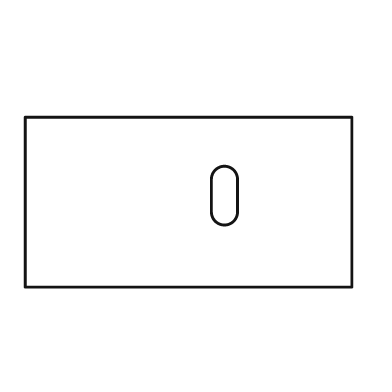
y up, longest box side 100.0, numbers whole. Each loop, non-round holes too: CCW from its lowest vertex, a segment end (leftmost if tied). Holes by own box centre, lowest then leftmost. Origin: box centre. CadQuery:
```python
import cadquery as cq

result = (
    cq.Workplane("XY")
    .moveTo(-50.0, -26.0)
    .lineTo(50.0, -26.0)
    .lineTo(50.0, 26.0)
    .lineTo(-50.0, 26.0)
    .close()
    .moveTo(7.0, -3.0)
    .threePointArc((11.0, -7.0), (15.0, -3.0))
    .lineTo(15.0, 7.0)
    .threePointArc((11.0, 11.0), (7.0, 7.0))
    .close()
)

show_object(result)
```